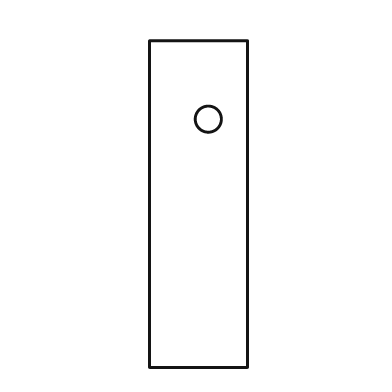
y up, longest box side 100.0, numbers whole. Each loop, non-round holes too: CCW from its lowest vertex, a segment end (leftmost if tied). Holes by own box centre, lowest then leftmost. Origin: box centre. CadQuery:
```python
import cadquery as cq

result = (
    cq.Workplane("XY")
    .moveTo(-15.0, -50.0)
    .lineTo(15.0, -50.0)
    .lineTo(15.0, 50.0)
    .lineTo(-15.0, 50.0)
    .close()
    .moveTo(3.0, 26.0)
    .circle(4.0)
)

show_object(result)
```